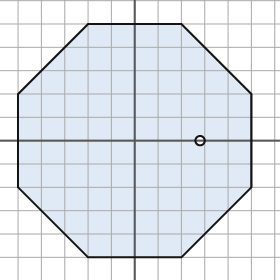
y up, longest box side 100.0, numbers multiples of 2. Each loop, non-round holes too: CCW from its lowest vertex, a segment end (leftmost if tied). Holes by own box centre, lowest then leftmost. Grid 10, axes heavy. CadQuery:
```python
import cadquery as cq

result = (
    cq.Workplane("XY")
    .moveTo(-20.0, -50.0)
    .lineTo(20.0, -50.0)
    .lineTo(50.0, -20.0)
    .lineTo(50.0, 20.0)
    .lineTo(20.0, 50.0)
    .lineTo(-20.0, 50.0)
    .lineTo(-50.0, 20.0)
    .lineTo(-50.0, -20.0)
    .close()
    .moveTo(28.0, 0.0)
    .circle(2.0)
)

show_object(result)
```